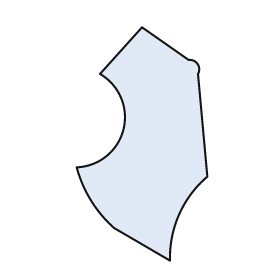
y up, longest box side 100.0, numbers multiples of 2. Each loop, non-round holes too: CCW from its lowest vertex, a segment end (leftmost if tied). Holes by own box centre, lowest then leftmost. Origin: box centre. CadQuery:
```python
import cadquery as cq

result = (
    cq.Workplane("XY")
    .moveTo(12.0, -50.0)
    .threePointArc((16.0, -30.0), (28.0, -14.0))
    .lineTo(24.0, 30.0)
    .threePointArc((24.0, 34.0), (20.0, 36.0))
    .lineTo(0.0, 50.0)
    .lineTo(-18.0, 30.0)
    .threePointArc((-8.0, 6.0), (-28.0, -10.0))
    .threePointArc((-22.0, -24.0), (-12.0, -36.0))
    .close()
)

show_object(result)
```